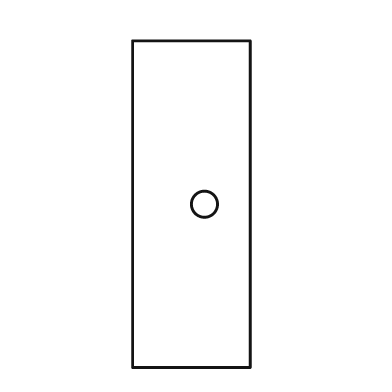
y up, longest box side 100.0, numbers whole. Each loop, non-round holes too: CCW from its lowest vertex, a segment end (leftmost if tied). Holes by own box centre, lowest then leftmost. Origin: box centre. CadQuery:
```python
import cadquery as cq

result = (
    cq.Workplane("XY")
    .moveTo(-18.0, -50.0)
    .lineTo(18.0, -50.0)
    .lineTo(18.0, 50.0)
    .lineTo(-18.0, 50.0)
    .close()
    .moveTo(4.0, 0.0)
    .circle(4.0)
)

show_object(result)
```